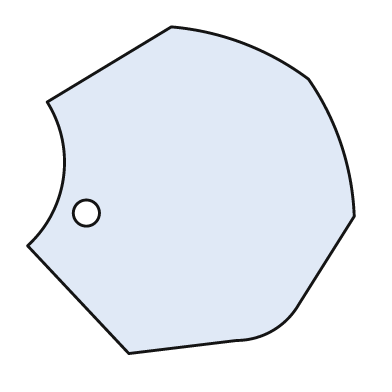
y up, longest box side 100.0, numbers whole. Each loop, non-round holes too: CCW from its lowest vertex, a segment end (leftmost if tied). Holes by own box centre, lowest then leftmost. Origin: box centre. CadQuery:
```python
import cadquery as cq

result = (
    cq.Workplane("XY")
    .moveTo(-19.0, -50.0)
    .lineTo(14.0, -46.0)
    .threePointArc((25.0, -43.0), (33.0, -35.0))
    .lineTo(50.0, -8.0)
    .threePointArc((46.0, 14.0), (36.0, 34.0))
    .threePointArc((16.0, 45.0), (-6.0, 50.0))
    .lineTo(-44.0, 27.0)
    .threePointArc((-39.0, 4.0), (-50.0, -17.0))
    .close()
    .moveTo(-32.0, -7.0)
    .circle(4.0)
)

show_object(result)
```